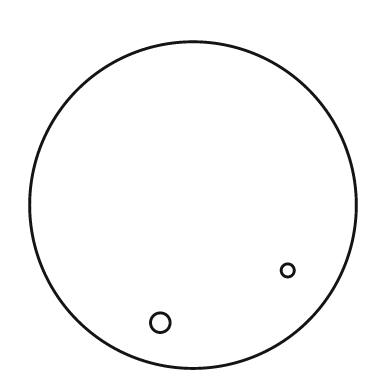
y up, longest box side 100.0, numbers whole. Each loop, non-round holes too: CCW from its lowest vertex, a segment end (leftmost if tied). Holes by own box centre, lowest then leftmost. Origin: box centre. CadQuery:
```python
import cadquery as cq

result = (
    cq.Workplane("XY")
    .moveTo(0.0, 0.0)
    .circle(50.0)
    .moveTo(-10.0, -36.0)
    .circle(3.0)
    .moveTo(29.0, -20.0)
    .circle(2.0)
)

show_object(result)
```